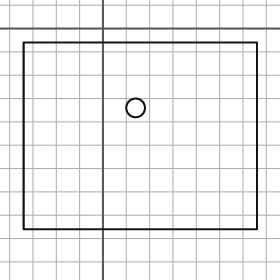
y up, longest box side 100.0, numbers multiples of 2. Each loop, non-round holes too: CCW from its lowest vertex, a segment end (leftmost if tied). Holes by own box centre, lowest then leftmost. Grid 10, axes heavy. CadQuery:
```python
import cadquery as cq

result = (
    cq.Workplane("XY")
    .moveTo(-34.0, -86.0)
    .lineTo(66.0, -86.0)
    .lineTo(66.0, -6.0)
    .lineTo(-34.0, -6.0)
    .close()
    .moveTo(14.0, -34.0)
    .circle(4.0)
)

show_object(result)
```